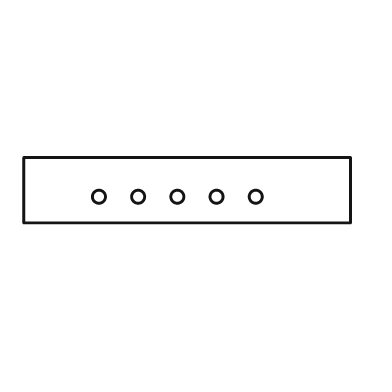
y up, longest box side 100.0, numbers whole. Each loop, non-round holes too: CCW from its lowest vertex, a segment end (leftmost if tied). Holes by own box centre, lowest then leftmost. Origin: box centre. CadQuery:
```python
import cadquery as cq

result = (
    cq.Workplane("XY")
    .moveTo(-50.0, -10.0)
    .lineTo(50.0, -10.0)
    .lineTo(50.0, 10.0)
    .lineTo(-50.0, 10.0)
    .close()
    .moveTo(-27.0, -2.0)
    .circle(2.0)
    .moveTo(-15.0, -2.0)
    .circle(2.0)
    .moveTo(-3.0, -2.0)
    .circle(2.0)
    .moveTo(9.0, -2.0)
    .circle(2.0)
    .moveTo(21.0, -2.0)
    .circle(2.0)
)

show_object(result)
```